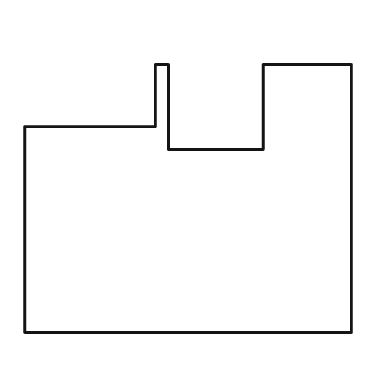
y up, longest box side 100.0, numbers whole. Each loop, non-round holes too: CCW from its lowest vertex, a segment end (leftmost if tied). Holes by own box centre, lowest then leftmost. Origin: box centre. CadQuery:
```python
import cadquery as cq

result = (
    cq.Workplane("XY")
    .moveTo(-50.0, -41.0)
    .lineTo(50.0, -41.0)
    .lineTo(50.0, 41.0)
    .lineTo(23.0, 41.0)
    .lineTo(23.0, 15.0)
    .lineTo(-6.0, 15.0)
    .lineTo(-6.0, 41.0)
    .lineTo(-10.0, 41.0)
    .lineTo(-10.0, 22.0)
    .lineTo(-50.0, 22.0)
    .close()
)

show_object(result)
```